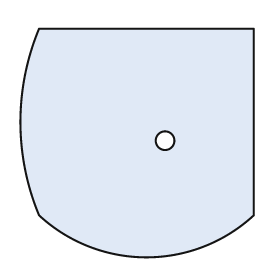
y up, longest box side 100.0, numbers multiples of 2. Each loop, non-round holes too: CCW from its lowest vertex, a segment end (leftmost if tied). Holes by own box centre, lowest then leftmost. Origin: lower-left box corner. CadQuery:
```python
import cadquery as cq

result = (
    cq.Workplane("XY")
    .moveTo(8.0, 18.0)
    .threePointArc((54.0, 0.0), (100.0, 18.0))
    .lineTo(100.0, 98.0)
    .lineTo(8.0, 98.0)
    .threePointArc((0.0, 58.0), (8.0, 18.0))
    .close()
    .moveTo(62.0, 50.0)
    .circle(4.0)
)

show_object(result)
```